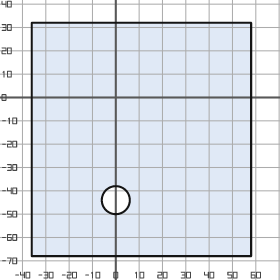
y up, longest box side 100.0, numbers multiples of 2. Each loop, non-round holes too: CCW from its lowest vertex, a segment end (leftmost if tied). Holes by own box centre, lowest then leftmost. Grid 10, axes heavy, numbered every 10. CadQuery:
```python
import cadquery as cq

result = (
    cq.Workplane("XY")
    .moveTo(-36.0, -68.0)
    .lineTo(58.0, -68.0)
    .lineTo(58.0, 32.0)
    .lineTo(-36.0, 32.0)
    .close()
    .moveTo(0.0, -44.0)
    .circle(6.0)
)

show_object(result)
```